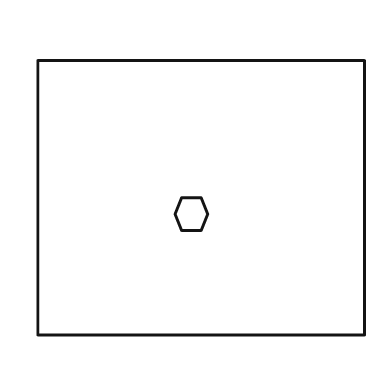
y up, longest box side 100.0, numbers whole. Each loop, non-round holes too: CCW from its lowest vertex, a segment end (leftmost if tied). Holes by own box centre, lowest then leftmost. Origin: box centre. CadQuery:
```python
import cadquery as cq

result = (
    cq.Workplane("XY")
    .moveTo(-50.0, -42.0)
    .lineTo(50.0, -42.0)
    .lineTo(50.0, 42.0)
    .lineTo(-50.0, 42.0)
    .close()
    .moveTo(-6.0, -10.0)
    .lineTo(0.0, -10.0)
    .lineTo(2.0, -5.0)
    .lineTo(0.0, 0.0)
    .lineTo(-6.0, 0.0)
    .lineTo(-8.0, -5.0)
    .close()
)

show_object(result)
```